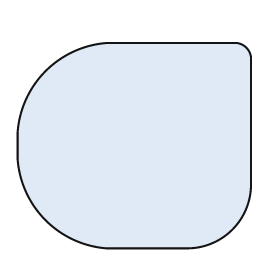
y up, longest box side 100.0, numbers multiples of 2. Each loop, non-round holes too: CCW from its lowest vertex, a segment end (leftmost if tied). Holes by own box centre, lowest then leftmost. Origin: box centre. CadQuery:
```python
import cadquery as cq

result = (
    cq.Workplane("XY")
    .moveTo(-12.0, -44.0)
    .lineTo(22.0, -44.0)
    .threePointArc((42.0, -36.0), (50.0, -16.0))
    .lineTo(50.0, 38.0)
    .threePointArc((48.0, 42.0), (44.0, 44.0))
    .lineTo(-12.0, 44.0)
    .threePointArc((-38.0, 32.0), (-50.0, 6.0))
    .lineTo(-50.0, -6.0)
    .threePointArc((-38.0, -32.0), (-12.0, -44.0))
    .close()
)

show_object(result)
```